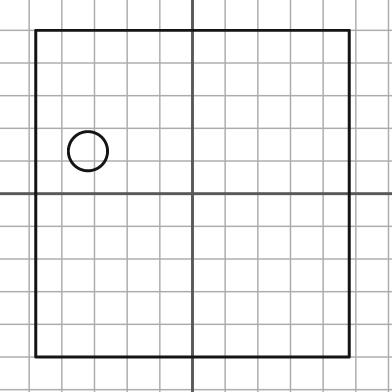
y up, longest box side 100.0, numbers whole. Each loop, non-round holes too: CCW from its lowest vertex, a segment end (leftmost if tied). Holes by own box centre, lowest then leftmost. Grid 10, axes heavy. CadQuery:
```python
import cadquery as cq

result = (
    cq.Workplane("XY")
    .moveTo(-48.0, -50.0)
    .lineTo(48.0, -50.0)
    .lineTo(48.0, 50.0)
    .lineTo(-48.0, 50.0)
    .close()
    .moveTo(-32.0, 13.0)
    .circle(6.0)
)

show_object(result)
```